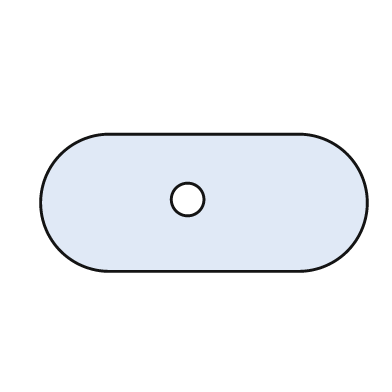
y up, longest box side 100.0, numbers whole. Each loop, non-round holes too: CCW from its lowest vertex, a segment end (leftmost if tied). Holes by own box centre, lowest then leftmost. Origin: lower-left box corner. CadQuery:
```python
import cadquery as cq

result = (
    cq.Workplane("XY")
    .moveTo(21.0, 0.0)
    .lineTo(79.0, 0.0)
    .threePointArc((100.0, 21.0), (79.0, 42.0))
    .lineTo(21.0, 42.0)
    .threePointArc((0.0, 21.0), (21.0, 0.0))
    .close()
    .moveTo(45.0, 22.0)
    .circle(5.0)
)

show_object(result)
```